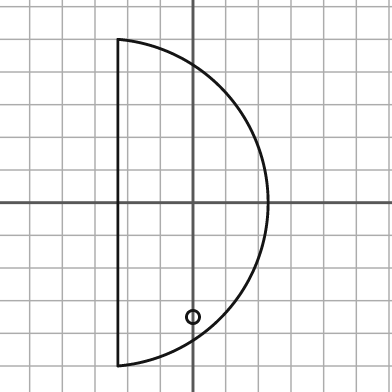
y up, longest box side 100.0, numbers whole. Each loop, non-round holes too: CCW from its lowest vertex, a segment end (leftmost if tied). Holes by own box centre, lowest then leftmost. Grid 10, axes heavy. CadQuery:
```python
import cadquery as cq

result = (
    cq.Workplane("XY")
    .moveTo(-23.0, -50.0)
    .threePointArc((23.0, 0.0), (-23.0, 50.0))
    .close()
    .moveTo(0.0, -35.0)
    .circle(2.0)
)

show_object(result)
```